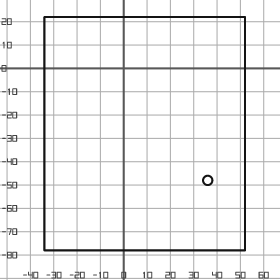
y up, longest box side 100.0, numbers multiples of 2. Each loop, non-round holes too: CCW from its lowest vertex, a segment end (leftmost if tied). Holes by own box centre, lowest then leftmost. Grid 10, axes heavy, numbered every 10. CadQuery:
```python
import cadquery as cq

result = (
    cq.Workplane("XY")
    .moveTo(-34.0, -78.0)
    .lineTo(52.0, -78.0)
    .lineTo(52.0, 22.0)
    .lineTo(-34.0, 22.0)
    .close()
    .moveTo(36.0, -48.0)
    .circle(2.0)
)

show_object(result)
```